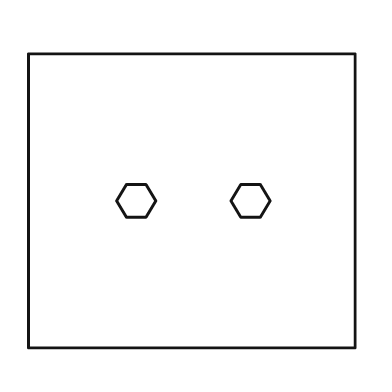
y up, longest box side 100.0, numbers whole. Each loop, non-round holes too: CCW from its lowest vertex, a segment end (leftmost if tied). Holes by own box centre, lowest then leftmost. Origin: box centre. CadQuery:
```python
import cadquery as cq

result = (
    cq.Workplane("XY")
    .moveTo(-50.0, -45.0)
    .lineTo(50.0, -45.0)
    .lineTo(50.0, 45.0)
    .lineTo(-50.0, 45.0)
    .close()
    .moveTo(-20.0, -5.0)
    .lineTo(-14.0, -5.0)
    .lineTo(-11.0, 0.0)
    .lineTo(-14.0, 5.0)
    .lineTo(-20.0, 5.0)
    .lineTo(-23.0, 0.0)
    .close()
    .moveTo(15.0, -5.0)
    .lineTo(21.0, -5.0)
    .lineTo(24.0, 0.0)
    .lineTo(21.0, 5.0)
    .lineTo(15.0, 5.0)
    .lineTo(12.0, 0.0)
    .close()
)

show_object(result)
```